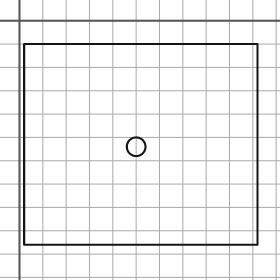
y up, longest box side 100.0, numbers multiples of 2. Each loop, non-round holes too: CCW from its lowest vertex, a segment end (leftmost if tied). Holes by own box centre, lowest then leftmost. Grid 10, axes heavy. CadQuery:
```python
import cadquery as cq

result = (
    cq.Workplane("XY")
    .moveTo(2.0, -96.0)
    .lineTo(102.0, -96.0)
    .lineTo(102.0, -10.0)
    .lineTo(2.0, -10.0)
    .close()
    .moveTo(50.0, -54.0)
    .circle(4.0)
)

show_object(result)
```